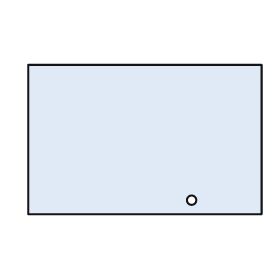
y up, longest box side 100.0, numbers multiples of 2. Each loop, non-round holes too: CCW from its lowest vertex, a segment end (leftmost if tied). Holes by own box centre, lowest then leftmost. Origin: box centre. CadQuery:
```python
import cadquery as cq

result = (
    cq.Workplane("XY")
    .moveTo(-50.0, -32.0)
    .lineTo(50.0, -32.0)
    .lineTo(50.0, 32.0)
    .lineTo(-50.0, 32.0)
    .close()
    .moveTo(20.0, -26.0)
    .circle(2.0)
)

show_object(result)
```